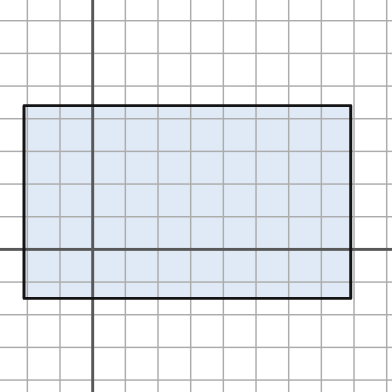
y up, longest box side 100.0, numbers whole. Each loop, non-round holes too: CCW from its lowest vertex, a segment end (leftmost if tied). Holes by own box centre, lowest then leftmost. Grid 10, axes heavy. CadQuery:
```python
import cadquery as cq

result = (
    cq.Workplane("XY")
    .moveTo(-21.0, -15.0)
    .lineTo(79.0, -15.0)
    .lineTo(79.0, 44.0)
    .lineTo(-21.0, 44.0)
    .close()
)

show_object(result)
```